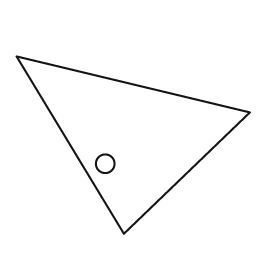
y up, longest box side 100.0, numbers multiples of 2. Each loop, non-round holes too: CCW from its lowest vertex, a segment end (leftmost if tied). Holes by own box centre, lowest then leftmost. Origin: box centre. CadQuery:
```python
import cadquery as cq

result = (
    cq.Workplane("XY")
    .moveTo(-4.0, -38.0)
    .lineTo(50.0, 14.0)
    .lineTo(-50.0, 38.0)
    .close()
    .moveTo(-12.0, -8.0)
    .circle(4.0)
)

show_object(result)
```